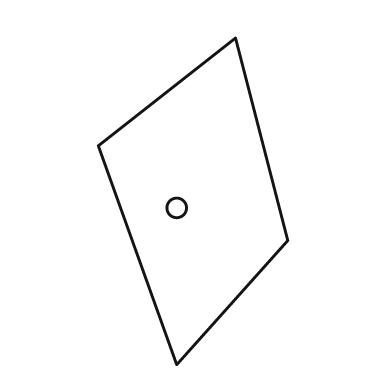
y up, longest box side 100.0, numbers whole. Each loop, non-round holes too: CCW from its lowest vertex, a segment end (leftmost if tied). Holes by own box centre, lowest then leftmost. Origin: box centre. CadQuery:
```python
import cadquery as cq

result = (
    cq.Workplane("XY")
    .moveTo(-5.0, -50.0)
    .lineTo(29.0, -12.0)
    .lineTo(13.0, 50.0)
    .lineTo(-29.0, 17.0)
    .close()
    .moveTo(-5.0, -2.0)
    .circle(3.0)
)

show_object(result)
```